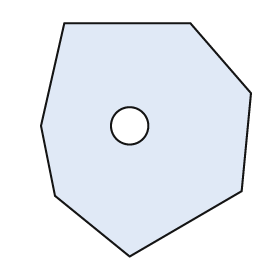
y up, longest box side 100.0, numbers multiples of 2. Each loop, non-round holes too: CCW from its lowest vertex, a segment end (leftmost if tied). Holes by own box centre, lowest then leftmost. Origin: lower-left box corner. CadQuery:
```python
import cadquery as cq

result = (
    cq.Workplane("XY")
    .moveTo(38.0, 0.0)
    .lineTo(86.0, 28.0)
    .lineTo(90.0, 70.0)
    .lineTo(64.0, 100.0)
    .lineTo(10.0, 100.0)
    .lineTo(0.0, 56.0)
    .lineTo(6.0, 26.0)
    .close()
    .moveTo(38.0, 56.0)
    .circle(8.0)
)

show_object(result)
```